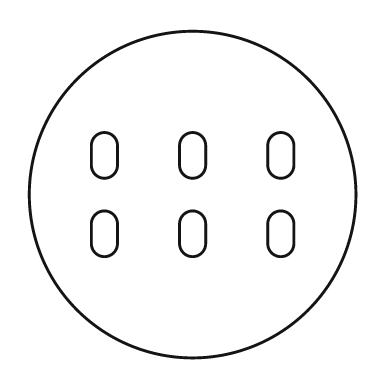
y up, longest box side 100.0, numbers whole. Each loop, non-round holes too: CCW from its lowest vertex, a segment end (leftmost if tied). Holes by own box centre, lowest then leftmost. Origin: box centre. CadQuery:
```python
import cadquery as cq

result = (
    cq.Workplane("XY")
    .moveTo(0.0, 0.0)
    .circle(50.0)
    .moveTo(-31.0, -15.0)
    .threePointArc((-27.0, -19.0), (-23.0, -15.0))
    .lineTo(-23.0, -9.0)
    .threePointArc((-27.0, -5.0), (-31.0, -9.0))
    .close()
    .moveTo(-4.0, -15.0)
    .threePointArc((0.0, -19.0), (4.0, -15.0))
    .lineTo(4.0, -9.0)
    .threePointArc((0.0, -5.0), (-4.0, -9.0))
    .close()
    .moveTo(23.0, -15.0)
    .threePointArc((27.0, -19.0), (31.0, -15.0))
    .lineTo(31.0, -9.0)
    .threePointArc((27.0, -5.0), (23.0, -9.0))
    .close()
    .moveTo(-31.0, 9.0)
    .threePointArc((-27.0, 5.0), (-23.0, 9.0))
    .lineTo(-23.0, 15.0)
    .threePointArc((-27.0, 19.0), (-31.0, 15.0))
    .close()
    .moveTo(-4.0, 9.0)
    .threePointArc((0.0, 5.0), (4.0, 9.0))
    .lineTo(4.0, 15.0)
    .threePointArc((0.0, 19.0), (-4.0, 15.0))
    .close()
    .moveTo(23.0, 9.0)
    .threePointArc((27.0, 5.0), (31.0, 9.0))
    .lineTo(31.0, 15.0)
    .threePointArc((27.0, 19.0), (23.0, 15.0))
    .close()
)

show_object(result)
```